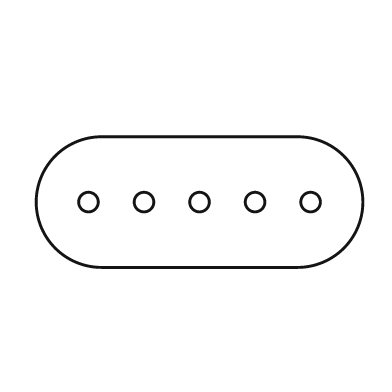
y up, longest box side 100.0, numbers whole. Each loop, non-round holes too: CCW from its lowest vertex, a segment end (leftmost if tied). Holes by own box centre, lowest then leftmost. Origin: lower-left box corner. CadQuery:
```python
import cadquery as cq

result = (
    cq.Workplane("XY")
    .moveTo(20.0, 0.0)
    .lineTo(80.0, 0.0)
    .threePointArc((100.0, 20.0), (80.0, 40.0))
    .lineTo(20.0, 40.0)
    .threePointArc((0.0, 20.0), (20.0, 0.0))
    .close()
    .moveTo(16.0, 20.0)
    .circle(3.0)
    .moveTo(33.0, 20.0)
    .circle(3.0)
    .moveTo(50.0, 20.0)
    .circle(3.0)
    .moveTo(67.0, 20.0)
    .circle(3.0)
    .moveTo(84.0, 20.0)
    .circle(3.0)
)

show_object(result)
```